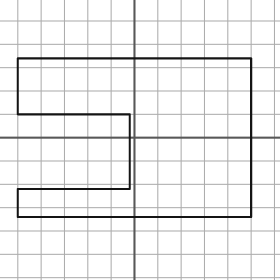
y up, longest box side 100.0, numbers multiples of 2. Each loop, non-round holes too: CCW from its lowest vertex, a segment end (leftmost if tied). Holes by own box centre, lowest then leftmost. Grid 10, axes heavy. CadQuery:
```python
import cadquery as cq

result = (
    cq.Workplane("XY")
    .moveTo(-50.0, -34.0)
    .lineTo(50.0, -34.0)
    .lineTo(50.0, 34.0)
    .lineTo(-50.0, 34.0)
    .lineTo(-50.0, 10.0)
    .lineTo(-2.0, 10.0)
    .lineTo(-2.0, -22.0)
    .lineTo(-50.0, -22.0)
    .close()
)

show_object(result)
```